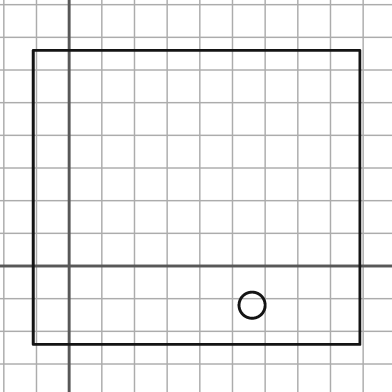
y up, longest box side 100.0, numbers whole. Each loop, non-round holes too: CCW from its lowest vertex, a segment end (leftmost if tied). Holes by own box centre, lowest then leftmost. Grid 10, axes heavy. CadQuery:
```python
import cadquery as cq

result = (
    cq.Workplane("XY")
    .moveTo(-11.0, -24.0)
    .lineTo(89.0, -24.0)
    .lineTo(89.0, 66.0)
    .lineTo(-11.0, 66.0)
    .close()
    .moveTo(56.0, -12.0)
    .circle(4.0)
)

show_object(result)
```